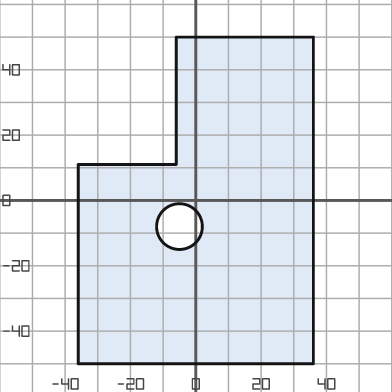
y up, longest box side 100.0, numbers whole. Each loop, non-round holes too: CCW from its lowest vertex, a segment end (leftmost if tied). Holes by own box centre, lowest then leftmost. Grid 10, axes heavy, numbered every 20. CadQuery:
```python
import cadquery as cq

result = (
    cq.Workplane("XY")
    .moveTo(-36.0, -50.0)
    .lineTo(36.0, -50.0)
    .lineTo(36.0, 50.0)
    .lineTo(-6.0, 50.0)
    .lineTo(-6.0, 11.0)
    .lineTo(-36.0, 11.0)
    .close()
    .moveTo(-5.0, -8.0)
    .circle(7.0)
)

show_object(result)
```